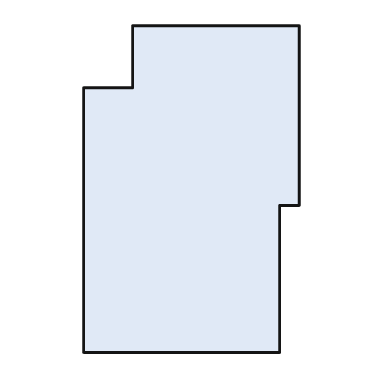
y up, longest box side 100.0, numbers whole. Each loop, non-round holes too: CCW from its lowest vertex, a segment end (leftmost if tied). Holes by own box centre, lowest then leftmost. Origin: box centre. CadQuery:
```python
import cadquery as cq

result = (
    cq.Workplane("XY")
    .moveTo(-33.0, -50.0)
    .lineTo(27.0, -50.0)
    .lineTo(27.0, -5.0)
    .lineTo(33.0, -5.0)
    .lineTo(33.0, 50.0)
    .lineTo(-18.0, 50.0)
    .lineTo(-18.0, 31.0)
    .lineTo(-33.0, 31.0)
    .close()
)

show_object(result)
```